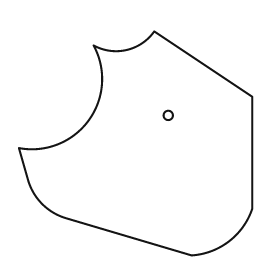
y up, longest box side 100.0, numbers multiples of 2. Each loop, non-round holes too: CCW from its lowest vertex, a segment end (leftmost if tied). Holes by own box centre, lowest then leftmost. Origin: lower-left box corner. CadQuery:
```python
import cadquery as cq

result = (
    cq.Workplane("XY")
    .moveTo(74.0, 0.0)
    .threePointArc((90.0, 6.0), (100.0, 20.0))
    .lineTo(100.0, 68.0)
    .lineTo(58.0, 96.0)
    .threePointArc((46.0, 88.0), (32.0, 90.0))
    .threePointArc((30.0, 58.0), (0.0, 46.0))
    .lineTo(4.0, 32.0)
    .threePointArc((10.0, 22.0), (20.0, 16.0))
    .close()
    .moveTo(64.0, 60.0)
    .circle(2.0)
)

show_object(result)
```